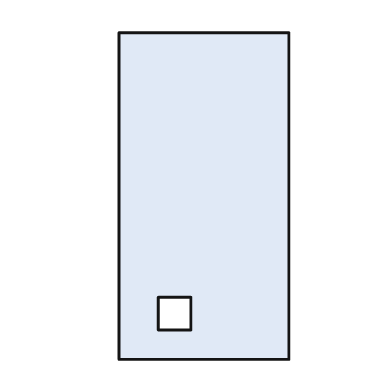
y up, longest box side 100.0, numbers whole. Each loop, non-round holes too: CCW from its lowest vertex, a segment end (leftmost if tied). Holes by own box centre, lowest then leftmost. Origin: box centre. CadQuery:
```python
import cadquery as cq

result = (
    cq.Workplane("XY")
    .moveTo(-26.0, -50.0)
    .lineTo(26.0, -50.0)
    .lineTo(26.0, 50.0)
    .lineTo(-26.0, 50.0)
    .close()
    .moveTo(-14.0, -41.0)
    .lineTo(-4.0, -41.0)
    .lineTo(-4.0, -31.0)
    .lineTo(-14.0, -31.0)
    .close()
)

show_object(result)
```